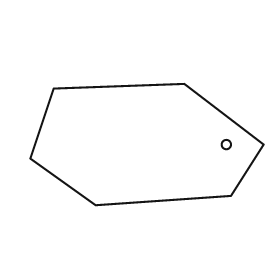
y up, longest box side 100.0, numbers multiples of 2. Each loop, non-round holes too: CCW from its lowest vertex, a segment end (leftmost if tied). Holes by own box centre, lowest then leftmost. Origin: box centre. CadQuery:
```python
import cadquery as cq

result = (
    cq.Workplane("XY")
    .moveTo(-22.0, -26.0)
    .lineTo(36.0, -22.0)
    .lineTo(50.0, 0.0)
    .lineTo(16.0, 26.0)
    .lineTo(-40.0, 24.0)
    .lineTo(-50.0, -6.0)
    .close()
    .moveTo(34.0, 0.0)
    .circle(2.0)
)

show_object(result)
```